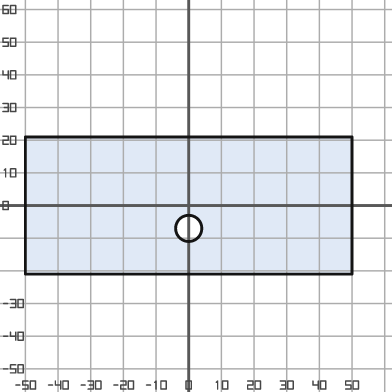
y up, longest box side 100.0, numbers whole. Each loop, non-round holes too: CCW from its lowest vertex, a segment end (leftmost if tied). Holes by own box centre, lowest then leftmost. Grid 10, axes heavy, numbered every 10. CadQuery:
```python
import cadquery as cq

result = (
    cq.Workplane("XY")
    .moveTo(-50.0, -21.0)
    .lineTo(50.0, -21.0)
    .lineTo(50.0, 21.0)
    .lineTo(-50.0, 21.0)
    .close()
    .moveTo(0.0, -7.0)
    .circle(4.0)
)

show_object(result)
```